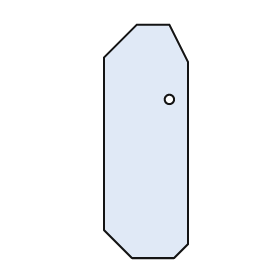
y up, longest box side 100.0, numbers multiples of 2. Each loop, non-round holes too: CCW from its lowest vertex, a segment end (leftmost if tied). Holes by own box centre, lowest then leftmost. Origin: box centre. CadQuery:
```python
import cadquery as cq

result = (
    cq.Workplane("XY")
    .moveTo(-6.0, -50.0)
    .lineTo(12.0, -50.0)
    .lineTo(18.0, -44.0)
    .lineTo(18.0, 34.0)
    .lineTo(10.0, 50.0)
    .lineTo(-4.0, 50.0)
    .lineTo(-18.0, 36.0)
    .lineTo(-18.0, -38.0)
    .close()
    .moveTo(10.0, 18.0)
    .circle(2.0)
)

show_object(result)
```